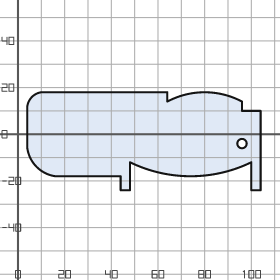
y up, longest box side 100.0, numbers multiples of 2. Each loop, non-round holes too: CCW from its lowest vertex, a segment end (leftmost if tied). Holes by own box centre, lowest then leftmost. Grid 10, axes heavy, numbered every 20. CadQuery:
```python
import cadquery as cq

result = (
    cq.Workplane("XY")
    .moveTo(44.0, -24.0)
    .lineTo(48.0, -24.0)
    .lineTo(48.0, -12.0)
    .threePointArc((74.0, -18.0), (100.0, -12.0))
    .lineTo(100.0, -24.0)
    .lineTo(104.0, -24.0)
    .lineTo(104.0, 10.0)
    .lineTo(96.0, 10.0)
    .lineTo(96.0, 14.0)
    .threePointArc((80.0, 18.0), (64.0, 14.0))
    .lineTo(64.0, 18.0)
    .lineTo(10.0, 18.0)
    .threePointArc((6.0, 16.0), (4.0, 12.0))
    .lineTo(4.0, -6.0)
    .threePointArc((8.0, -14.0), (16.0, -18.0))
    .lineTo(44.0, -18.0)
    .close()
    .moveTo(96.0, -4.0)
    .circle(2.0)
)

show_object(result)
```